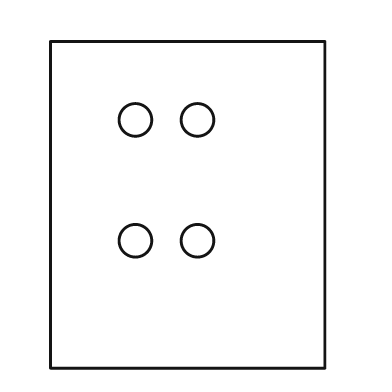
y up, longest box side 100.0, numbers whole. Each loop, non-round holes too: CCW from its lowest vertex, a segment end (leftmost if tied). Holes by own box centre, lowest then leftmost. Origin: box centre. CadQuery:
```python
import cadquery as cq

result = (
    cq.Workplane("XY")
    .moveTo(-42.0, -50.0)
    .lineTo(42.0, -50.0)
    .lineTo(42.0, 50.0)
    .lineTo(-42.0, 50.0)
    .close()
    .moveTo(-16.0, -11.0)
    .circle(5.0)
    .moveTo(3.0, -11.0)
    .circle(5.0)
    .moveTo(-16.0, 26.0)
    .circle(5.0)
    .moveTo(3.0, 26.0)
    .circle(5.0)
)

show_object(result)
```